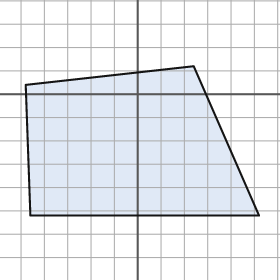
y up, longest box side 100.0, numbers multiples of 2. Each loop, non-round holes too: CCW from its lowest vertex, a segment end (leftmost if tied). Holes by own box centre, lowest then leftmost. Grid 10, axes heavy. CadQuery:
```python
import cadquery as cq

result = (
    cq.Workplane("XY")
    .moveTo(-46.0, -52.0)
    .lineTo(52.0, -52.0)
    .lineTo(24.0, 12.0)
    .lineTo(-48.0, 4.0)
    .close()
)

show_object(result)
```